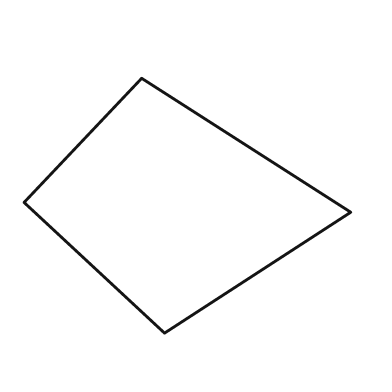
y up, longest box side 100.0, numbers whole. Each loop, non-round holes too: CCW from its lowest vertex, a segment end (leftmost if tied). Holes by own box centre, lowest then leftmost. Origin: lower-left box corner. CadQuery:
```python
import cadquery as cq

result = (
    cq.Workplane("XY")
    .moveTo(43.0, 0.0)
    .lineTo(100.0, 37.0)
    .lineTo(36.0, 78.0)
    .lineTo(0.0, 40.0)
    .close()
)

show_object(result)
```